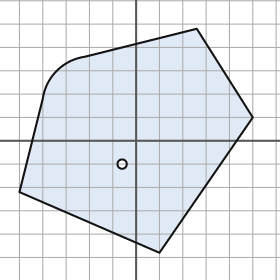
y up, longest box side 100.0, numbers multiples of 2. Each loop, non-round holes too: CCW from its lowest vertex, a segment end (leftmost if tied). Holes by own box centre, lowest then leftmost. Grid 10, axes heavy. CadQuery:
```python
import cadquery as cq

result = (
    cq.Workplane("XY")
    .moveTo(10.0, -48.0)
    .lineTo(50.0, 10.0)
    .lineTo(26.0, 48.0)
    .lineTo(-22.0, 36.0)
    .threePointArc((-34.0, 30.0), (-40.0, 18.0))
    .lineTo(-50.0, -22.0)
    .close()
    .moveTo(-6.0, -10.0)
    .circle(2.0)
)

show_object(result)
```